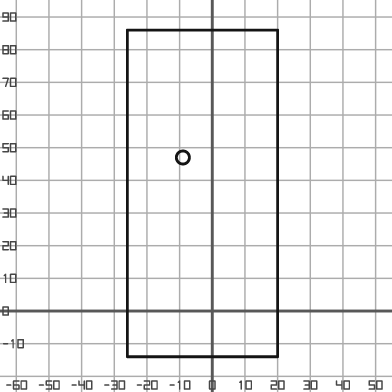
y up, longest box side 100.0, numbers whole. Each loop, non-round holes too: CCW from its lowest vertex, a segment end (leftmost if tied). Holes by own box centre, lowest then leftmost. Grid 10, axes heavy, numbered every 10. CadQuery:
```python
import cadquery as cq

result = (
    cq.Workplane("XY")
    .moveTo(-26.0, -14.0)
    .lineTo(20.0, -14.0)
    .lineTo(20.0, 86.0)
    .lineTo(-26.0, 86.0)
    .close()
    .moveTo(-9.0, 47.0)
    .circle(2.0)
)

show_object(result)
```